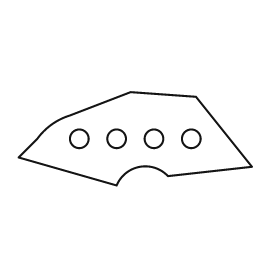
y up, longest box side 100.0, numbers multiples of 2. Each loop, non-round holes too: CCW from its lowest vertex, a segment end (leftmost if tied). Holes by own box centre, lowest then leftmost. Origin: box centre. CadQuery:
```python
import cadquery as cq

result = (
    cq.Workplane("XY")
    .moveTo(-8.0, -20.0)
    .threePointArc((2.0, -12.0), (14.0, -16.0))
    .lineTo(50.0, -12.0)
    .lineTo(26.0, 18.0)
    .lineTo(-2.0, 20.0)
    .lineTo(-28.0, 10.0)
    .threePointArc((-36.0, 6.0), (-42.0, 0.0))
    .lineTo(-50.0, -8.0)
    .close()
    .moveTo(-24.0, 0.0)
    .circle(4.0)
    .moveTo(-8.0, 0.0)
    .circle(4.0)
    .moveTo(8.0, 0.0)
    .circle(4.0)
    .moveTo(24.0, 0.0)
    .circle(4.0)
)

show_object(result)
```